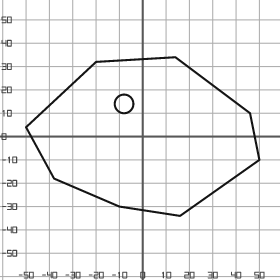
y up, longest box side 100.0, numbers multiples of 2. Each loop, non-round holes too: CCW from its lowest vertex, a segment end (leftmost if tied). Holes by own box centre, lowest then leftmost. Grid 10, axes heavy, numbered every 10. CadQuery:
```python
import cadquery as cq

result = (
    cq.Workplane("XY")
    .moveTo(16.0, -34.0)
    .lineTo(50.0, -10.0)
    .lineTo(46.0, 10.0)
    .lineTo(14.0, 34.0)
    .lineTo(-20.0, 32.0)
    .lineTo(-50.0, 4.0)
    .lineTo(-38.0, -18.0)
    .lineTo(-10.0, -30.0)
    .close()
    .moveTo(-8.0, 14.0)
    .circle(4.0)
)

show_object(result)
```